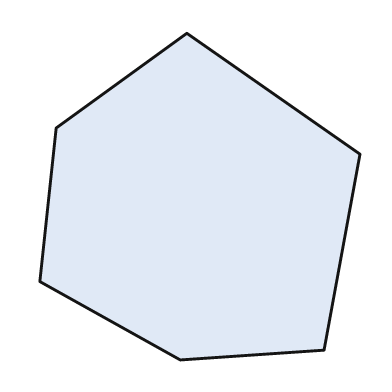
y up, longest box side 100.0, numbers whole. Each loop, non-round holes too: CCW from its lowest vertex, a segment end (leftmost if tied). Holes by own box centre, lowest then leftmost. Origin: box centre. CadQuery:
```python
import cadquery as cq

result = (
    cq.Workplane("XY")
    .moveTo(-6.0, -50.0)
    .lineTo(38.0, -47.0)
    .lineTo(49.0, 13.0)
    .lineTo(-4.0, 50.0)
    .lineTo(-44.0, 21.0)
    .lineTo(-49.0, -26.0)
    .close()
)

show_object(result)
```